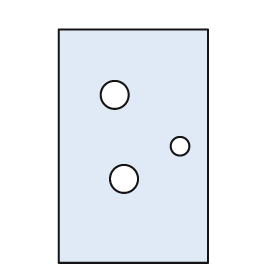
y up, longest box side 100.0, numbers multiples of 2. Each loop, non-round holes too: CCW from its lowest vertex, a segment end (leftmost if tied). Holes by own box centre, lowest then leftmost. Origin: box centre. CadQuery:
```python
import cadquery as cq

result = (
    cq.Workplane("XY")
    .moveTo(-32.0, -50.0)
    .lineTo(32.0, -50.0)
    .lineTo(32.0, 50.0)
    .lineTo(-32.0, 50.0)
    .close()
    .moveTo(-4.0, -14.0)
    .circle(6.0)
    .moveTo(20.0, 0.0)
    .circle(4.0)
    .moveTo(-8.0, 22.0)
    .circle(6.0)
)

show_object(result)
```